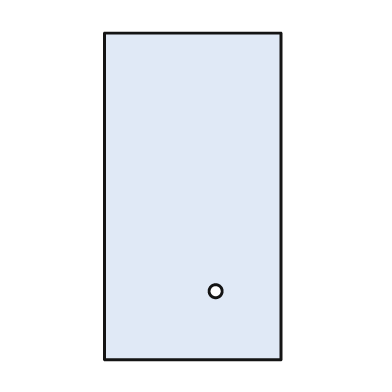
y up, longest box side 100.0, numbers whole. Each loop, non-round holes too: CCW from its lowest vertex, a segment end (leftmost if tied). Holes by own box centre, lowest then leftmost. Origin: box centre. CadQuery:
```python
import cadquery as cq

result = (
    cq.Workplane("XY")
    .moveTo(-27.0, -50.0)
    .lineTo(27.0, -50.0)
    .lineTo(27.0, 50.0)
    .lineTo(-27.0, 50.0)
    .close()
    .moveTo(7.0, -29.0)
    .circle(2.0)
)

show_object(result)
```